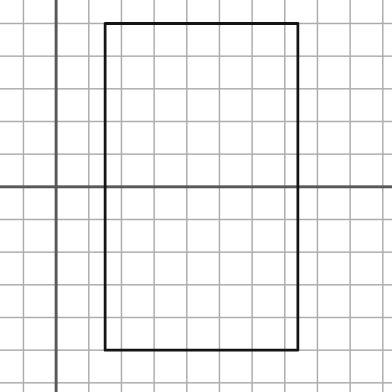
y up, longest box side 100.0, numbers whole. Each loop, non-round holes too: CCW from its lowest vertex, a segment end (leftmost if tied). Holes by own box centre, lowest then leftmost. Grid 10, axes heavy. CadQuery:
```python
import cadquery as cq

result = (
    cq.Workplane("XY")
    .moveTo(15.0, -50.0)
    .lineTo(74.0, -50.0)
    .lineTo(74.0, 50.0)
    .lineTo(15.0, 50.0)
    .close()
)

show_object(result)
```